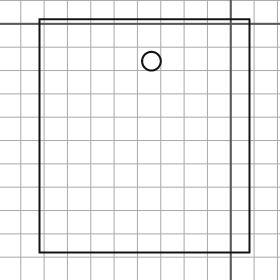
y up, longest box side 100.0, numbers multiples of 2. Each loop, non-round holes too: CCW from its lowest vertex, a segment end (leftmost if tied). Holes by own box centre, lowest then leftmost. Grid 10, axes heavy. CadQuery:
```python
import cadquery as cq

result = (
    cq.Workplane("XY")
    .moveTo(-82.0, -98.0)
    .lineTo(8.0, -98.0)
    .lineTo(8.0, 2.0)
    .lineTo(-82.0, 2.0)
    .close()
    .moveTo(-34.0, -16.0)
    .circle(4.0)
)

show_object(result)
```